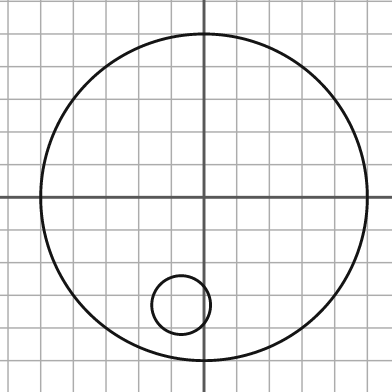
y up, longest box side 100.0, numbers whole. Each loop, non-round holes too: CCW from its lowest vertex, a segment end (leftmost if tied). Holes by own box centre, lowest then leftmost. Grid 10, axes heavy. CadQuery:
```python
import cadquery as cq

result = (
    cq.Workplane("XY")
    .moveTo(0.0, 0.0)
    .circle(50.0)
    .moveTo(-7.0, -33.0)
    .circle(9.0)
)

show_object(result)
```